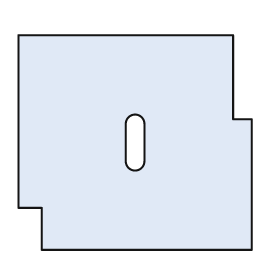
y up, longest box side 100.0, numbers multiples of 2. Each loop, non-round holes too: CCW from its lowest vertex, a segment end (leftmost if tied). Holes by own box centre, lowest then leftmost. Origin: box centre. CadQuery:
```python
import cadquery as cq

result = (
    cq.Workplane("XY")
    .moveTo(-40.0, -46.0)
    .lineTo(50.0, -46.0)
    .lineTo(50.0, 10.0)
    .lineTo(42.0, 10.0)
    .lineTo(42.0, 46.0)
    .lineTo(-50.0, 46.0)
    .lineTo(-50.0, -28.0)
    .lineTo(-40.0, -28.0)
    .close()
    .moveTo(-4.0, -8.0)
    .threePointArc((0.0, -12.0), (4.0, -8.0))
    .lineTo(4.0, 8.0)
    .threePointArc((0.0, 12.0), (-4.0, 8.0))
    .close()
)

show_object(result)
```